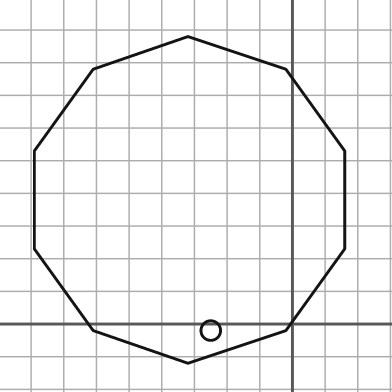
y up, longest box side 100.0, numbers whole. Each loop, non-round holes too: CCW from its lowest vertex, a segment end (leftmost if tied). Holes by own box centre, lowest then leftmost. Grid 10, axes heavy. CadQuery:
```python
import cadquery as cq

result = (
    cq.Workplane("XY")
    .moveTo(-32.0, -12.0)
    .lineTo(-2.0, -2.0)
    .lineTo(16.0, 23.0)
    .lineTo(16.0, 53.0)
    .lineTo(-2.0, 78.0)
    .lineTo(-32.0, 88.0)
    .lineTo(-61.0, 78.0)
    .lineTo(-79.0, 53.0)
    .lineTo(-79.0, 23.0)
    .lineTo(-61.0, -2.0)
    .close()
    .moveTo(-25.0, -2.0)
    .circle(3.0)
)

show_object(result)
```